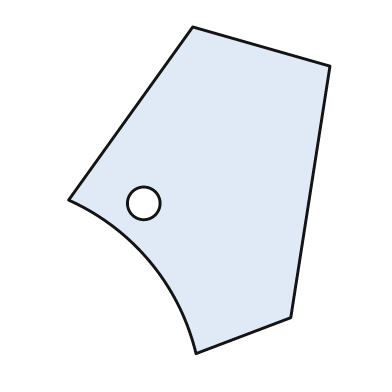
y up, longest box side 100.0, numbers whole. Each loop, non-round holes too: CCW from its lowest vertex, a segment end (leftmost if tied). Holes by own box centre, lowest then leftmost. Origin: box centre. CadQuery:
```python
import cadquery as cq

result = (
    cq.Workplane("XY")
    .moveTo(-1.0, -50.0)
    .lineTo(28.0, -39.0)
    .lineTo(40.0, 38.0)
    .lineTo(-2.0, 50.0)
    .lineTo(-40.0, -3.0)
    .threePointArc((-15.0, -22.0), (-1.0, -50.0))
    .close()
    .moveTo(-17.0, -4.0)
    .circle(5.0)
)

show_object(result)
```